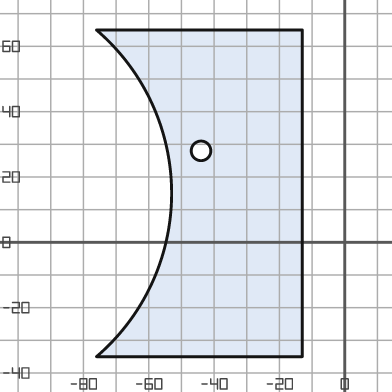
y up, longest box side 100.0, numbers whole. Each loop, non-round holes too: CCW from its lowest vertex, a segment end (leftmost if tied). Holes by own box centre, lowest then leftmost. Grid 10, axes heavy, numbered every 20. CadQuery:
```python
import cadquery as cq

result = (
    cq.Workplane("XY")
    .moveTo(-76.0, -35.0)
    .lineTo(-13.0, -35.0)
    .lineTo(-13.0, 65.0)
    .lineTo(-76.0, 65.0)
    .threePointArc((-53.0, 15.0), (-76.0, -35.0))
    .close()
    .moveTo(-44.0, 28.0)
    .circle(3.0)
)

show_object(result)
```